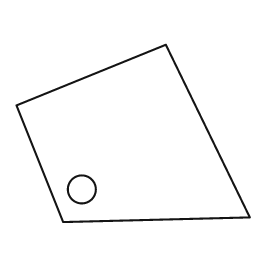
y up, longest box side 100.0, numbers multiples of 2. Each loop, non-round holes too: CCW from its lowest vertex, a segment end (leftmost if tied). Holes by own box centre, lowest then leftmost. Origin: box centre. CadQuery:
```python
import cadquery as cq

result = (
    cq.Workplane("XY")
    .moveTo(-30.0, -38.0)
    .lineTo(50.0, -36.0)
    .lineTo(14.0, 38.0)
    .lineTo(-50.0, 12.0)
    .close()
    .moveTo(-22.0, -24.0)
    .circle(6.0)
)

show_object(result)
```